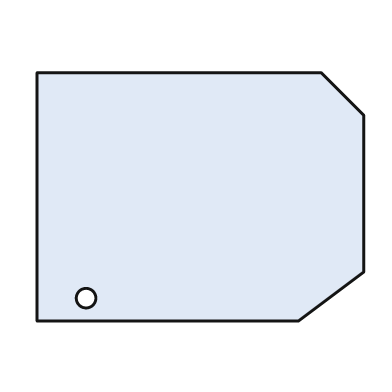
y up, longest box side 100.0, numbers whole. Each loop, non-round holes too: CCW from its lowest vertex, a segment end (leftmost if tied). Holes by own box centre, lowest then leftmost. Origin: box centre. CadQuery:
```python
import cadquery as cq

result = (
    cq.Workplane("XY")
    .moveTo(-50.0, -38.0)
    .lineTo(30.0, -38.0)
    .lineTo(50.0, -23.0)
    .lineTo(50.0, 25.0)
    .lineTo(37.0, 38.0)
    .lineTo(-50.0, 38.0)
    .close()
    .moveTo(-35.0, -31.0)
    .circle(3.0)
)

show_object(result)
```